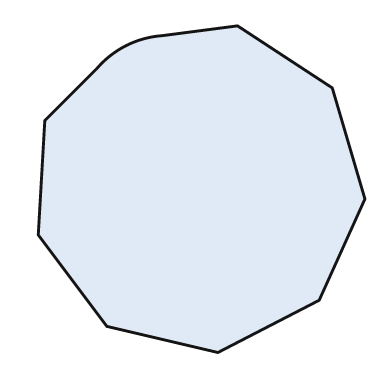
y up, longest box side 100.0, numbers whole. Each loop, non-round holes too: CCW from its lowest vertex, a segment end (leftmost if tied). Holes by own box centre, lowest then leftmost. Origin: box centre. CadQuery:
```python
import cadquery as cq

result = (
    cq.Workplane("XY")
    .moveTo(5.0, -50.0)
    .lineTo(36.0, -34.0)
    .lineTo(50.0, -3.0)
    .lineTo(40.0, 31.0)
    .lineTo(11.0, 50.0)
    .lineTo(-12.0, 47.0)
    .threePointArc((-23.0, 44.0), (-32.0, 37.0))
    .lineTo(-48.0, 21.0)
    .lineTo(-50.0, -14.0)
    .lineTo(-29.0, -42.0)
    .close()
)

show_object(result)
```